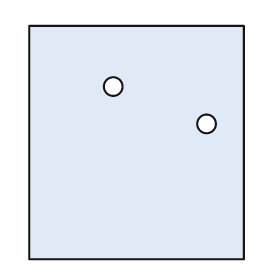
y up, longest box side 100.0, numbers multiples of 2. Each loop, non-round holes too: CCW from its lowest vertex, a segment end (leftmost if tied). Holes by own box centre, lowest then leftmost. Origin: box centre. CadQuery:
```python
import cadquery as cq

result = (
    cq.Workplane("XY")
    .moveTo(-46.0, -50.0)
    .lineTo(46.0, -50.0)
    .lineTo(46.0, 50.0)
    .lineTo(-46.0, 50.0)
    .close()
    .moveTo(30.0, 8.0)
    .circle(4.0)
    .moveTo(-10.0, 24.0)
    .circle(4.0)
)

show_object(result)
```